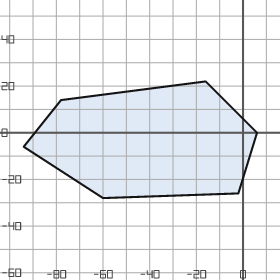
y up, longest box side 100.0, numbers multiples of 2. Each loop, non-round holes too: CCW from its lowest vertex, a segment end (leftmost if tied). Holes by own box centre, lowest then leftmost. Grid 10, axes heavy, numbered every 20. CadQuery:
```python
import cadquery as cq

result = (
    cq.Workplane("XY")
    .moveTo(-60.0, -28.0)
    .lineTo(-2.0, -26.0)
    .lineTo(6.0, 0.0)
    .lineTo(-16.0, 22.0)
    .lineTo(-78.0, 14.0)
    .lineTo(-94.0, -6.0)
    .close()
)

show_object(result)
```